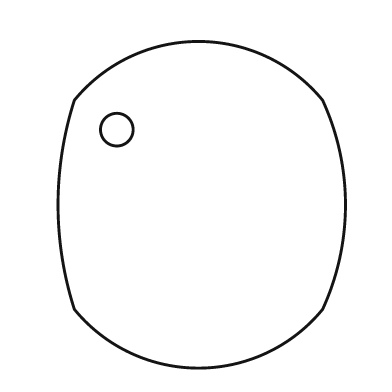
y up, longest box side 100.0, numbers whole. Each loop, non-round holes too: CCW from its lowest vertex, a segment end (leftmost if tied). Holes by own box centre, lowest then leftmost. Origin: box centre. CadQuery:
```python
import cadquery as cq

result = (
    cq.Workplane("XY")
    .moveTo(-39.0, -32.0)
    .threePointArc((-1.0, -50.0), (37.0, -32.0))
    .threePointArc((44.0, 0.0), (37.0, 32.0))
    .threePointArc((-1.0, 50.0), (-39.0, 32.0))
    .threePointArc((-44.0, 0.0), (-39.0, -32.0))
    .close()
    .moveTo(-26.0, 23.0)
    .circle(5.0)
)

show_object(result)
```